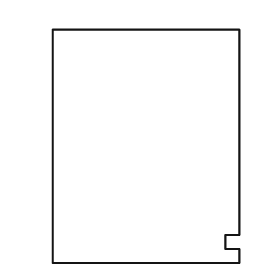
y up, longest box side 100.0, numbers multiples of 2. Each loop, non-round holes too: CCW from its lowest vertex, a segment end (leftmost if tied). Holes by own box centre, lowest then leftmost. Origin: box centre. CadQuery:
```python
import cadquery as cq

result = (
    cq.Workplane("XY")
    .moveTo(-40.0, -50.0)
    .lineTo(40.0, -50.0)
    .lineTo(40.0, -44.0)
    .lineTo(34.0, -44.0)
    .lineTo(34.0, -38.0)
    .lineTo(40.0, -38.0)
    .lineTo(40.0, 50.0)
    .lineTo(-40.0, 50.0)
    .close()
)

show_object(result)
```